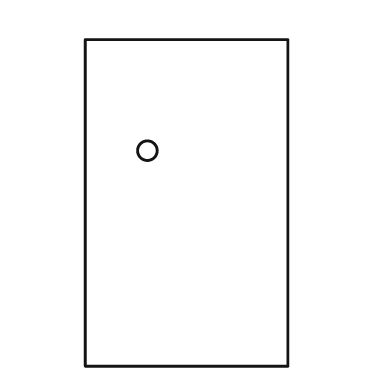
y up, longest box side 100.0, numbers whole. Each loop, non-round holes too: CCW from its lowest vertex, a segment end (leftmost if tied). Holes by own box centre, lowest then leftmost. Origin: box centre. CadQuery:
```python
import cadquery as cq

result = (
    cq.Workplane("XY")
    .moveTo(-31.0, -50.0)
    .lineTo(31.0, -50.0)
    .lineTo(31.0, 50.0)
    .lineTo(-31.0, 50.0)
    .close()
    .moveTo(-12.0, 16.0)
    .circle(3.0)
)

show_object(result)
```